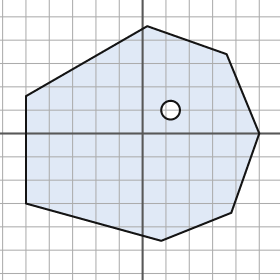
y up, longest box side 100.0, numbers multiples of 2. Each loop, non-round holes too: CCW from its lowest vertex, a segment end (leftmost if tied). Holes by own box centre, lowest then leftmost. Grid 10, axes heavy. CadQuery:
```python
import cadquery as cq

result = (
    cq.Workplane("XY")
    .moveTo(8.0, -46.0)
    .lineTo(38.0, -34.0)
    .lineTo(50.0, 0.0)
    .lineTo(36.0, 34.0)
    .lineTo(2.0, 46.0)
    .lineTo(-50.0, 16.0)
    .lineTo(-50.0, -30.0)
    .close()
    .moveTo(12.0, 10.0)
    .circle(4.0)
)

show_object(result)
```